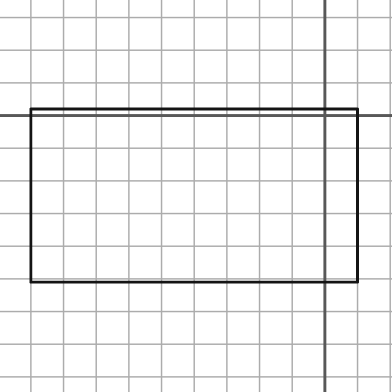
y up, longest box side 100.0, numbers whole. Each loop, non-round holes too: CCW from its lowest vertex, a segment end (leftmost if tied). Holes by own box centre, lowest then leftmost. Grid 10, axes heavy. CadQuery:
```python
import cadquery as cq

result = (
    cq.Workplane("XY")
    .moveTo(-90.0, -51.0)
    .lineTo(10.0, -51.0)
    .lineTo(10.0, 2.0)
    .lineTo(-90.0, 2.0)
    .close()
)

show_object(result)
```